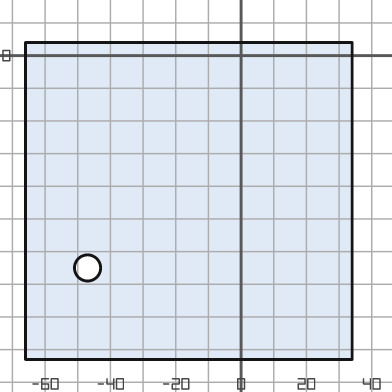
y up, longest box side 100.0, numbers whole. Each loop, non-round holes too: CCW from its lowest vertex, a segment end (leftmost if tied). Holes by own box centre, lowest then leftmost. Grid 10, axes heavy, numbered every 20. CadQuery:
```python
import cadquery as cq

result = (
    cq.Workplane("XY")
    .moveTo(-66.0, -93.0)
    .lineTo(34.0, -93.0)
    .lineTo(34.0, 4.0)
    .lineTo(-66.0, 4.0)
    .close()
    .moveTo(-47.0, -65.0)
    .circle(4.0)
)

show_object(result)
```